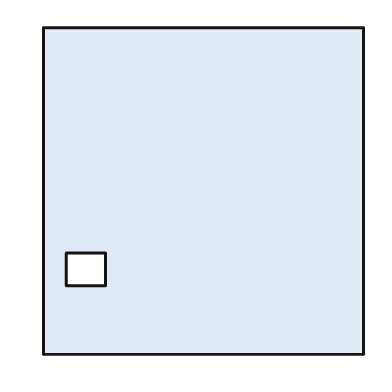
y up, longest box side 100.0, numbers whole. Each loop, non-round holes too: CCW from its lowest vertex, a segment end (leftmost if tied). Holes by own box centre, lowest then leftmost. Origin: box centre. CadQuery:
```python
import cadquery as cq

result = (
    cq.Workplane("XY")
    .moveTo(-49.0, -50.0)
    .lineTo(49.0, -50.0)
    .lineTo(49.0, 50.0)
    .lineTo(-49.0, 50.0)
    .close()
    .moveTo(-42.0, -29.0)
    .lineTo(-30.0, -29.0)
    .lineTo(-30.0, -19.0)
    .lineTo(-42.0, -19.0)
    .close()
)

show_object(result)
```